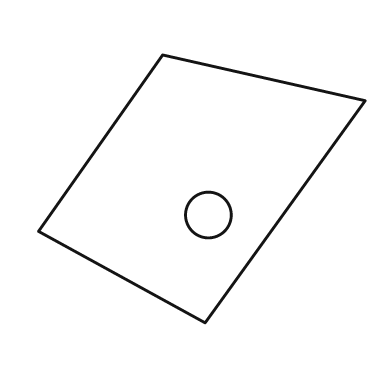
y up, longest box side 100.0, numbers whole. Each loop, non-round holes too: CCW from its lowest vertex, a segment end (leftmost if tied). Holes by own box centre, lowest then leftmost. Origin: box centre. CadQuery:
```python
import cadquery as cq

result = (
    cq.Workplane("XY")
    .moveTo(1.0, -41.0)
    .lineTo(50.0, 27.0)
    .lineTo(-12.0, 41.0)
    .lineTo(-50.0, -13.0)
    .close()
    .moveTo(2.0, -8.0)
    .circle(7.0)
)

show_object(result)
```